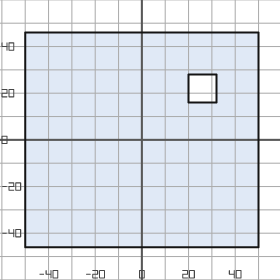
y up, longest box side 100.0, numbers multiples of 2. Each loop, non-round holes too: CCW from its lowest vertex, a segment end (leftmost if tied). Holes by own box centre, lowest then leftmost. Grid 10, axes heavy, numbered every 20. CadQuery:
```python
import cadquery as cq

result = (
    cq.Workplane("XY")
    .moveTo(-50.0, -46.0)
    .lineTo(50.0, -46.0)
    .lineTo(50.0, 46.0)
    .lineTo(-50.0, 46.0)
    .close()
    .moveTo(20.0, 16.0)
    .lineTo(32.0, 16.0)
    .lineTo(32.0, 28.0)
    .lineTo(20.0, 28.0)
    .close()
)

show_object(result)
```